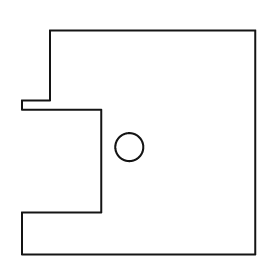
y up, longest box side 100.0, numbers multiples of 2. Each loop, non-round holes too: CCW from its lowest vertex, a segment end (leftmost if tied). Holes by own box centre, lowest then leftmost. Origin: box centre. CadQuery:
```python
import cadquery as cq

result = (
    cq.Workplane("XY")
    .moveTo(-50.0, -48.0)
    .lineTo(50.0, -48.0)
    .lineTo(50.0, 48.0)
    .lineTo(-38.0, 48.0)
    .lineTo(-38.0, 18.0)
    .lineTo(-50.0, 18.0)
    .lineTo(-50.0, 14.0)
    .lineTo(-16.0, 14.0)
    .lineTo(-16.0, -30.0)
    .lineTo(-50.0, -30.0)
    .close()
    .moveTo(-4.0, -2.0)
    .circle(6.0)
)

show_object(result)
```